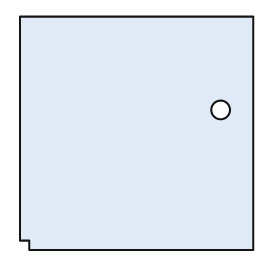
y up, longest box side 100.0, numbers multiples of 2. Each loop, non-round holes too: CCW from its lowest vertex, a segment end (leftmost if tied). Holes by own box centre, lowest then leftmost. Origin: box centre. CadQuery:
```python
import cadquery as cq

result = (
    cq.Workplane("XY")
    .moveTo(-46.0, -50.0)
    .lineTo(50.0, -50.0)
    .lineTo(50.0, 50.0)
    .lineTo(-50.0, 50.0)
    .lineTo(-50.0, -46.0)
    .lineTo(-46.0, -46.0)
    .close()
    .moveTo(36.0, 10.0)
    .circle(4.0)
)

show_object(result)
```